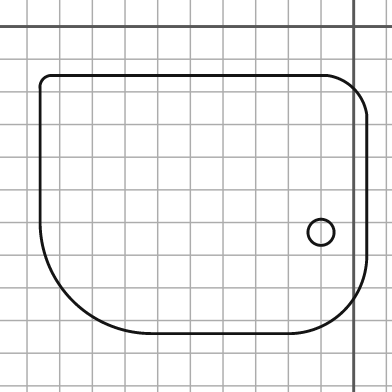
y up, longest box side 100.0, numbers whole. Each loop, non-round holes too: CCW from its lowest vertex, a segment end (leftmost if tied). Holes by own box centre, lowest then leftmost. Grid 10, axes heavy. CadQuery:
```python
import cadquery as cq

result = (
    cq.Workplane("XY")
    .moveTo(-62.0, -94.0)
    .lineTo(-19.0, -94.0)
    .threePointArc((-3.0, -87.0), (4.0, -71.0))
    .lineTo(4.0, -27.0)
    .threePointArc((0.0, -19.0), (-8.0, -15.0))
    .lineTo(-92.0, -15.0)
    .threePointArc((-95.0, -16.0), (-96.0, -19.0))
    .lineTo(-96.0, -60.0)
    .threePointArc((-86.0, -84.0), (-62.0, -94.0))
    .close()
    .moveTo(-10.0, -63.0)
    .circle(4.0)
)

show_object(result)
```